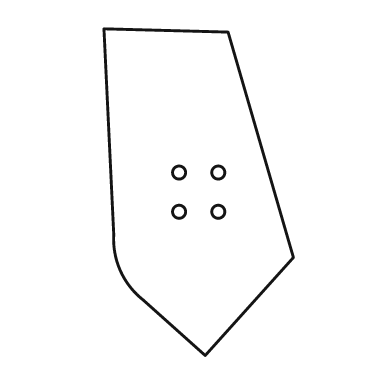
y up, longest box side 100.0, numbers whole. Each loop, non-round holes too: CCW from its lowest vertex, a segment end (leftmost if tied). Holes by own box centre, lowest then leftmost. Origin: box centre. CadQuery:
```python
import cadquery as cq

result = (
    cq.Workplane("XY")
    .moveTo(2.0, -50.0)
    .lineTo(29.0, -20.0)
    .lineTo(9.0, 49.0)
    .lineTo(-29.0, 50.0)
    .lineTo(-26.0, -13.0)
    .threePointArc((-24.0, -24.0), (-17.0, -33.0))
    .close()
    .moveTo(-6.0, -6.0)
    .circle(2.0)
    .moveTo(6.0, -6.0)
    .circle(2.0)
    .moveTo(-6.0, 6.0)
    .circle(2.0)
    .moveTo(6.0, 6.0)
    .circle(2.0)
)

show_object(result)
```